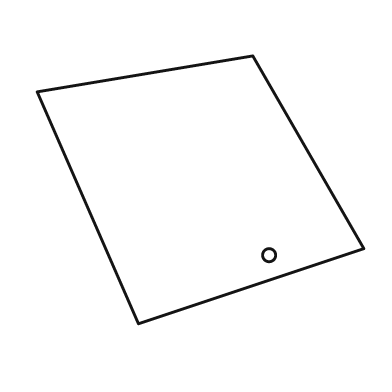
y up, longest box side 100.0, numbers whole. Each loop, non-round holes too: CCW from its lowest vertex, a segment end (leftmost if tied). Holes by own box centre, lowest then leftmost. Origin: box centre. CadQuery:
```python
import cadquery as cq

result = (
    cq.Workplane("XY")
    .moveTo(-19.0, -41.0)
    .lineTo(50.0, -18.0)
    .lineTo(16.0, 41.0)
    .lineTo(-50.0, 30.0)
    .close()
    .moveTo(21.0, -20.0)
    .circle(2.0)
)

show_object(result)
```